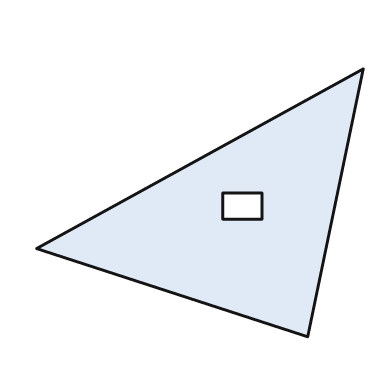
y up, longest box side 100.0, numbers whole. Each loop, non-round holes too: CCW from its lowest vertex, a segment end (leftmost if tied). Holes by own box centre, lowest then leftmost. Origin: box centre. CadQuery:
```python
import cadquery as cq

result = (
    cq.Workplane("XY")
    .moveTo(33.0, -41.0)
    .lineTo(50.0, 41.0)
    .lineTo(-50.0, -14.0)
    .close()
    .moveTo(7.0, -5.0)
    .lineTo(19.0, -5.0)
    .lineTo(19.0, 3.0)
    .lineTo(7.0, 3.0)
    .close()
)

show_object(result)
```